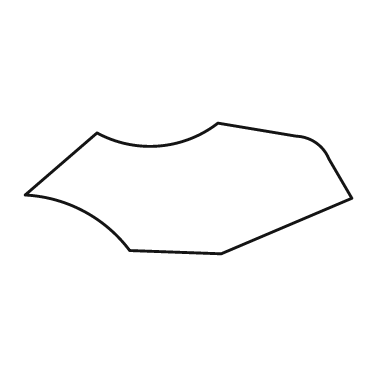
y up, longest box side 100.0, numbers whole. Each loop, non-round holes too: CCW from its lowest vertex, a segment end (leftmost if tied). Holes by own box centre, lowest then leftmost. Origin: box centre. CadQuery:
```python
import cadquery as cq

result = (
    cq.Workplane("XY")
    .moveTo(10.0, -20.0)
    .lineTo(50.0, -3.0)
    .lineTo(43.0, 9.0)
    .threePointArc((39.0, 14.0), (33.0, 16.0))
    .lineTo(9.0, 20.0)
    .threePointArc((-9.0, 13.0), (-28.0, 17.0))
    .lineTo(-50.0, -2.0)
    .threePointArc((-32.0, -7.0), (-18.0, -19.0))
    .close()
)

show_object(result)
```